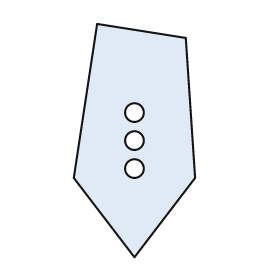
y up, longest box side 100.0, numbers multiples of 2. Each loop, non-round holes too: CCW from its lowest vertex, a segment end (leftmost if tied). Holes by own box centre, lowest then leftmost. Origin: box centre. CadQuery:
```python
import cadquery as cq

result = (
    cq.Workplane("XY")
    .moveTo(0.0, -50.0)
    .lineTo(26.0, -16.0)
    .lineTo(22.0, 44.0)
    .lineTo(-16.0, 50.0)
    .lineTo(-26.0, -16.0)
    .close()
    .moveTo(0.0, -12.0)
    .circle(4.0)
    .moveTo(0.0, 0.0)
    .circle(4.0)
    .moveTo(0.0, 12.0)
    .circle(4.0)
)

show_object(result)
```